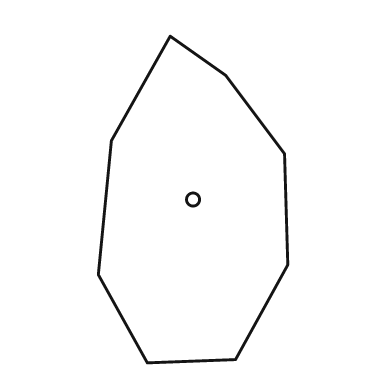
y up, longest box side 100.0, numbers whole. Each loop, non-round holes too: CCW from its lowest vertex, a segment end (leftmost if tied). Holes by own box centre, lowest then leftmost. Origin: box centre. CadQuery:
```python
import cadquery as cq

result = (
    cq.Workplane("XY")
    .moveTo(-14.0, -50.0)
    .lineTo(13.0, -49.0)
    .lineTo(29.0, -20.0)
    .lineTo(28.0, 14.0)
    .lineTo(10.0, 38.0)
    .lineTo(-7.0, 50.0)
    .lineTo(-25.0, 18.0)
    .lineTo(-29.0, -23.0)
    .close()
    .moveTo(0.0, 0.0)
    .circle(2.0)
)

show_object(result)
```